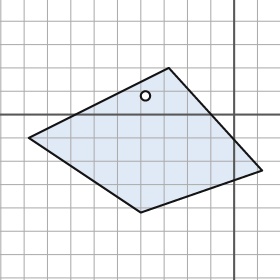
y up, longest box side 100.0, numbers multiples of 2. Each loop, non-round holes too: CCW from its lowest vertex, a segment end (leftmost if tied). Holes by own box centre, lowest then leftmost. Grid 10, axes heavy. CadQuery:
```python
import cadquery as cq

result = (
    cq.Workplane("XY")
    .moveTo(-40.0, -42.0)
    .lineTo(12.0, -24.0)
    .lineTo(-28.0, 20.0)
    .lineTo(-88.0, -10.0)
    .close()
    .moveTo(-38.0, 8.0)
    .circle(2.0)
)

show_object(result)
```